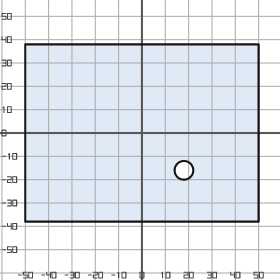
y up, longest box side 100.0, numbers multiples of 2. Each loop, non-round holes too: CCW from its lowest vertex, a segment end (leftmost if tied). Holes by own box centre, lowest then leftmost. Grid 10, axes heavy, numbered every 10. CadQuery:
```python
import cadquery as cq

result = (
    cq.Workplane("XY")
    .moveTo(-50.0, -38.0)
    .lineTo(50.0, -38.0)
    .lineTo(50.0, 38.0)
    .lineTo(-50.0, 38.0)
    .close()
    .moveTo(18.0, -16.0)
    .circle(4.0)
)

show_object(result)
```